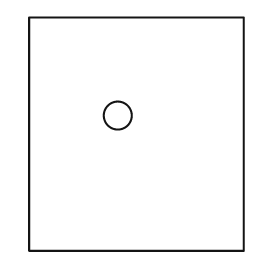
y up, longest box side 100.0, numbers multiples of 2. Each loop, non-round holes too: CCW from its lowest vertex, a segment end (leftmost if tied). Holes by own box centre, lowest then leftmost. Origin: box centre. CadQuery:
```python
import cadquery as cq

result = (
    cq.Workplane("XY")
    .moveTo(-46.0, -50.0)
    .lineTo(46.0, -50.0)
    .lineTo(46.0, 50.0)
    .lineTo(-46.0, 50.0)
    .close()
    .moveTo(-8.0, 8.0)
    .circle(6.0)
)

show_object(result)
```